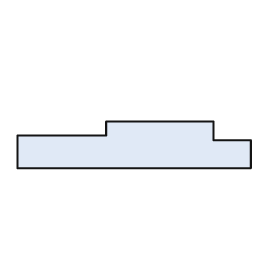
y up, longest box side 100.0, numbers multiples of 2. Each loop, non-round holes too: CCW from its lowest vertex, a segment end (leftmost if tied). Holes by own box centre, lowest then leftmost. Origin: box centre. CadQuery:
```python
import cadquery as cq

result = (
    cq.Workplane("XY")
    .moveTo(-50.0, -10.0)
    .lineTo(50.0, -10.0)
    .lineTo(50.0, 2.0)
    .lineTo(34.0, 2.0)
    .lineTo(34.0, 10.0)
    .lineTo(-12.0, 10.0)
    .lineTo(-12.0, 4.0)
    .lineTo(-50.0, 4.0)
    .close()
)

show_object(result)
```